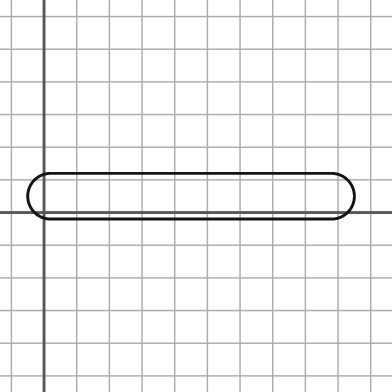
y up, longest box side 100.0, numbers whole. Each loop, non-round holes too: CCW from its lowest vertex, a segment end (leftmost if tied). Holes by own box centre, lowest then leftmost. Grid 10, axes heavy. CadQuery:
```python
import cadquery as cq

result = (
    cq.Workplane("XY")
    .moveTo(2.0, -2.0)
    .lineTo(88.0, -2.0)
    .threePointArc((95.0, 5.0), (88.0, 12.0))
    .lineTo(2.0, 12.0)
    .threePointArc((-5.0, 5.0), (2.0, -2.0))
    .close()
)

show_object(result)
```